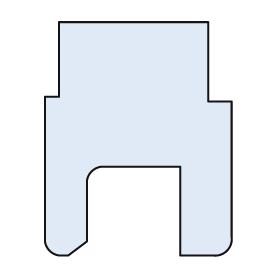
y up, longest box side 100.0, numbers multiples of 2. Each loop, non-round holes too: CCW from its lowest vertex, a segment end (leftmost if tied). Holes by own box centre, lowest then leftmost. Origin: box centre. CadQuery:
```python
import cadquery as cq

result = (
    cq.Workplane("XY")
    .moveTo(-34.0, -50.0)
    .lineTo(-30.0, -50.0)
    .lineTo(-22.0, -44.0)
    .lineTo(-22.0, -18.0)
    .threePointArc((-20.0, -14.0), (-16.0, -12.0))
    .lineTo(18.0, -12.0)
    .lineTo(18.0, -50.0)
    .lineTo(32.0, -50.0)
    .threePointArc((38.0, -48.0), (40.0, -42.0))
    .lineTo(40.0, 16.0)
    .lineTo(30.0, 16.0)
    .lineTo(30.0, 50.0)
    .lineTo(-34.0, 50.0)
    .lineTo(-34.0, 18.0)
    .lineTo(-40.0, 18.0)
    .lineTo(-40.0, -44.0)
    .threePointArc((-38.0, -48.0), (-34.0, -50.0))
    .close()
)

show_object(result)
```